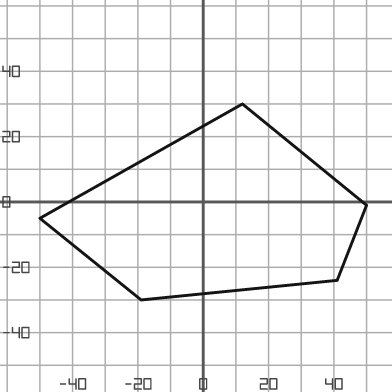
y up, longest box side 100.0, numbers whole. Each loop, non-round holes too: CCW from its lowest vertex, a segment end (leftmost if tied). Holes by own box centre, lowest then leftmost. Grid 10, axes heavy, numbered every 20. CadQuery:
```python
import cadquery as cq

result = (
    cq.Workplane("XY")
    .moveTo(-19.0, -30.0)
    .lineTo(41.0, -24.0)
    .lineTo(50.0, -1.0)
    .lineTo(12.0, 30.0)
    .lineTo(-50.0, -5.0)
    .close()
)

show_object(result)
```